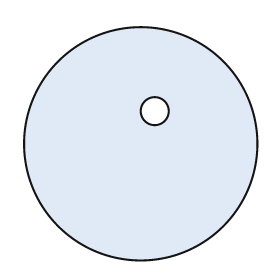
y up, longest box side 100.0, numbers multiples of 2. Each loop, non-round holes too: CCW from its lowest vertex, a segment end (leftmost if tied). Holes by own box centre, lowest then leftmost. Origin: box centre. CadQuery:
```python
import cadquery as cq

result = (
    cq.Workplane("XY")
    .moveTo(0.0, 0.0)
    .circle(50.0)
    .moveTo(6.0, 14.0)
    .circle(6.0)
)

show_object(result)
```